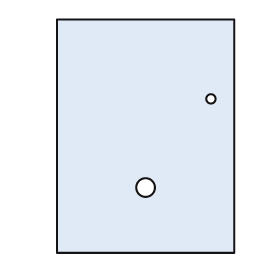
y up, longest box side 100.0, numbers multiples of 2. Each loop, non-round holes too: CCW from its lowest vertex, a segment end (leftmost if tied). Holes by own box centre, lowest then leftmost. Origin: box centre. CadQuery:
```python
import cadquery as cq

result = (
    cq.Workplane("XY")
    .moveTo(-38.0, -50.0)
    .lineTo(38.0, -50.0)
    .lineTo(38.0, 50.0)
    .lineTo(-38.0, 50.0)
    .close()
    .moveTo(0.0, -22.0)
    .circle(4.0)
    .moveTo(28.0, 16.0)
    .circle(2.0)
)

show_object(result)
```